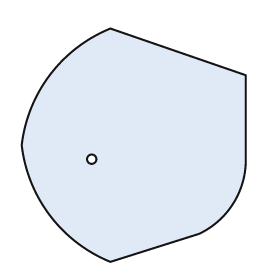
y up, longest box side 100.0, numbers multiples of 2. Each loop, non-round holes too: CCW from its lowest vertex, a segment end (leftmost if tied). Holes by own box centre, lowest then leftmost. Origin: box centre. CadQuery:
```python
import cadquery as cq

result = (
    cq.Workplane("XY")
    .moveTo(-10.0, -50.0)
    .lineTo(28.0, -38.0)
    .threePointArc((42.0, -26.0), (48.0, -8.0))
    .lineTo(48.0, 30.0)
    .lineTo(-10.0, 50.0)
    .threePointArc((-36.0, 30.0), (-48.0, 0.0))
    .threePointArc((-36.0, -30.0), (-10.0, -50.0))
    .close()
    .moveTo(-18.0, -6.0)
    .circle(2.0)
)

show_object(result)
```